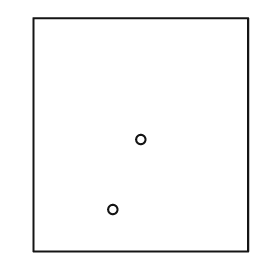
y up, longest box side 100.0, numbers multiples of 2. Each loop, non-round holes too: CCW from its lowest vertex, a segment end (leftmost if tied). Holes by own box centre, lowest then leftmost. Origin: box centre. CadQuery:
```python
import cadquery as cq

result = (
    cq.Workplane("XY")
    .moveTo(-46.0, -50.0)
    .lineTo(46.0, -50.0)
    .lineTo(46.0, 50.0)
    .lineTo(-46.0, 50.0)
    .close()
    .moveTo(-12.0, -32.0)
    .circle(2.0)
    .moveTo(0.0, -2.0)
    .circle(2.0)
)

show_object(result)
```